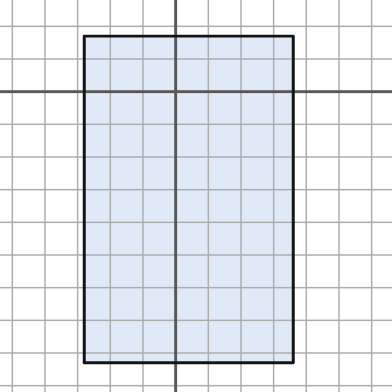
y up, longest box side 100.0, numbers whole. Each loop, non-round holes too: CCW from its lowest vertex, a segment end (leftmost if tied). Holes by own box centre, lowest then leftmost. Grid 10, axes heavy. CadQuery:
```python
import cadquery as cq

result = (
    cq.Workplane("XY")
    .moveTo(-28.0, -83.0)
    .lineTo(36.0, -83.0)
    .lineTo(36.0, 17.0)
    .lineTo(-28.0, 17.0)
    .close()
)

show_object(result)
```